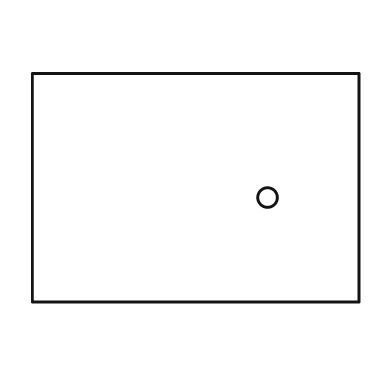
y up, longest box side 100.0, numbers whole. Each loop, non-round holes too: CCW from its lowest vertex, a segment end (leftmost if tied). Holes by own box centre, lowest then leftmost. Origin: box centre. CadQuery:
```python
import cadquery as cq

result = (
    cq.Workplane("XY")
    .moveTo(-50.0, -35.0)
    .lineTo(50.0, -35.0)
    .lineTo(50.0, 35.0)
    .lineTo(-50.0, 35.0)
    .close()
    .moveTo(22.0, -3.0)
    .circle(3.0)
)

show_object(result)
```